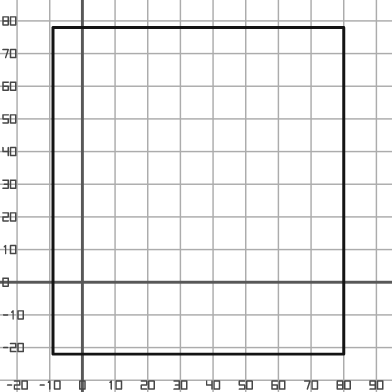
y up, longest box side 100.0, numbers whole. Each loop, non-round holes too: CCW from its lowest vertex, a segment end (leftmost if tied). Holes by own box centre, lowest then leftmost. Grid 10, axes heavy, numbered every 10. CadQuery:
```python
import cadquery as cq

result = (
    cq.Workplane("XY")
    .moveTo(-9.0, -22.0)
    .lineTo(80.0, -22.0)
    .lineTo(80.0, 78.0)
    .lineTo(-9.0, 78.0)
    .close()
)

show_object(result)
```